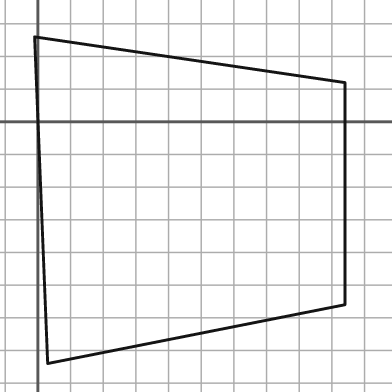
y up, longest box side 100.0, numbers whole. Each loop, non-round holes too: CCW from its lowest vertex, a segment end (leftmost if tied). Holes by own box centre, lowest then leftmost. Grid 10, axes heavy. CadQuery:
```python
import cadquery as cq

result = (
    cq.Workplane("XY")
    .moveTo(3.0, -74.0)
    .lineTo(94.0, -56.0)
    .lineTo(94.0, 12.0)
    .lineTo(-1.0, 26.0)
    .close()
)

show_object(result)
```